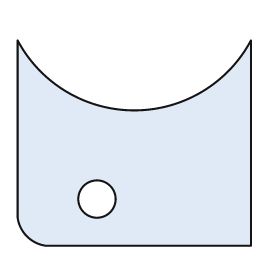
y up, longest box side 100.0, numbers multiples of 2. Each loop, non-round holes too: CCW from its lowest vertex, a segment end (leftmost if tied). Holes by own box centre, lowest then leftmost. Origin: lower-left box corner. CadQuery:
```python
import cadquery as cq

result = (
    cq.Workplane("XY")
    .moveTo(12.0, 0.0)
    .lineTo(100.0, 0.0)
    .lineTo(100.0, 88.0)
    .threePointArc((50.0, 58.0), (0.0, 88.0))
    .lineTo(0.0, 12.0)
    .threePointArc((4.0, 4.0), (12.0, 0.0))
    .close()
    .moveTo(34.0, 20.0)
    .circle(8.0)
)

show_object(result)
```